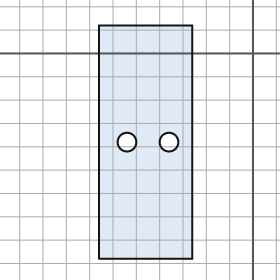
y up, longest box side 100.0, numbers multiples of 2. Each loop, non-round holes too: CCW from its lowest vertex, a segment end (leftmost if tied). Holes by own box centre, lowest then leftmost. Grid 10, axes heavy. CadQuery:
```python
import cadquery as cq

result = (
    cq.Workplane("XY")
    .moveTo(-66.0, -88.0)
    .lineTo(-26.0, -88.0)
    .lineTo(-26.0, 12.0)
    .lineTo(-66.0, 12.0)
    .close()
    .moveTo(-54.0, -38.0)
    .circle(4.0)
    .moveTo(-36.0, -38.0)
    .circle(4.0)
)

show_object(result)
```